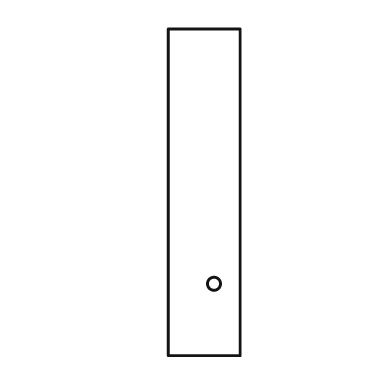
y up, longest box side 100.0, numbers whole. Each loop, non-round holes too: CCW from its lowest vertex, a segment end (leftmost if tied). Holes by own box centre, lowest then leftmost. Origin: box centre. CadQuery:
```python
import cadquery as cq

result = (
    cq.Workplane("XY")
    .moveTo(-11.0, -50.0)
    .lineTo(11.0, -50.0)
    .lineTo(11.0, 50.0)
    .lineTo(-11.0, 50.0)
    .close()
    .moveTo(3.0, -28.0)
    .circle(2.0)
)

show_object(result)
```